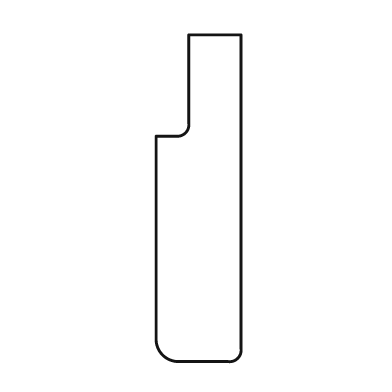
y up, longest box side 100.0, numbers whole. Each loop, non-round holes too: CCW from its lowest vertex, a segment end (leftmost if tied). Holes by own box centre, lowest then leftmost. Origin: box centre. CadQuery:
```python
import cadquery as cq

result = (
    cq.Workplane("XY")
    .moveTo(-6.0, -50.0)
    .lineTo(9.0, -50.0)
    .threePointArc((12.0, -49.0), (13.0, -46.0))
    .lineTo(13.0, 50.0)
    .lineTo(-3.0, 50.0)
    .lineTo(-3.0, 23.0)
    .threePointArc((-4.0, 20.0), (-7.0, 19.0))
    .lineTo(-13.0, 19.0)
    .lineTo(-13.0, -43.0)
    .threePointArc((-11.0, -48.0), (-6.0, -50.0))
    .close()
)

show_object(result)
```